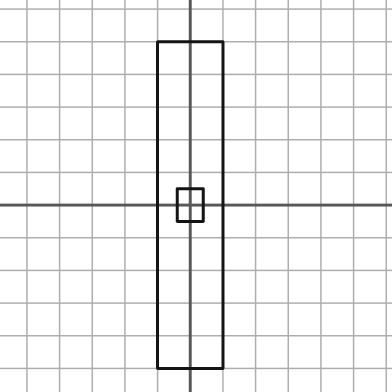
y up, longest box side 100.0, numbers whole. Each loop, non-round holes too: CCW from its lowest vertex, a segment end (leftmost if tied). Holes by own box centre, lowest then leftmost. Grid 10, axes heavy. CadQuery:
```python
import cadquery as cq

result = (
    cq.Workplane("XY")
    .moveTo(-10.0, -50.0)
    .lineTo(10.0, -50.0)
    .lineTo(10.0, 50.0)
    .lineTo(-10.0, 50.0)
    .close()
    .moveTo(-4.0, -5.0)
    .lineTo(4.0, -5.0)
    .lineTo(4.0, 5.0)
    .lineTo(-4.0, 5.0)
    .close()
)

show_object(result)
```